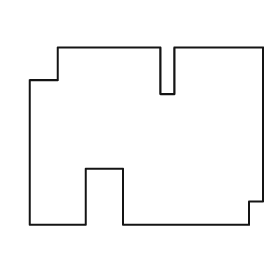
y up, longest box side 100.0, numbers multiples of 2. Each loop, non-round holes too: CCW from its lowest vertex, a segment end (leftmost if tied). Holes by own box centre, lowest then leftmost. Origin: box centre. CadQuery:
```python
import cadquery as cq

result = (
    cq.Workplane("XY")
    .moveTo(-50.0, -38.0)
    .lineTo(-26.0, -38.0)
    .lineTo(-26.0, -14.0)
    .lineTo(-10.0, -14.0)
    .lineTo(-10.0, -38.0)
    .lineTo(44.0, -38.0)
    .lineTo(44.0, -28.0)
    .lineTo(50.0, -28.0)
    .lineTo(50.0, 38.0)
    .lineTo(12.0, 38.0)
    .lineTo(12.0, 18.0)
    .lineTo(6.0, 18.0)
    .lineTo(6.0, 38.0)
    .lineTo(-38.0, 38.0)
    .lineTo(-38.0, 24.0)
    .lineTo(-50.0, 24.0)
    .close()
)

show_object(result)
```